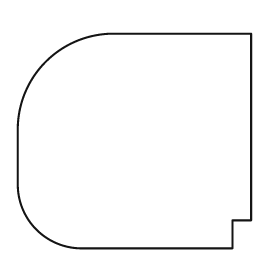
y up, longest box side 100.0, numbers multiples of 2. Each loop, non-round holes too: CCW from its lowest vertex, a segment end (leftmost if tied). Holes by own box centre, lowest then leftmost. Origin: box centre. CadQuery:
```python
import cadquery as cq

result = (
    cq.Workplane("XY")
    .moveTo(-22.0, -46.0)
    .lineTo(42.0, -46.0)
    .lineTo(42.0, -34.0)
    .lineTo(50.0, -34.0)
    .lineTo(50.0, 46.0)
    .lineTo(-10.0, 46.0)
    .threePointArc((-38.0, 34.0), (-50.0, 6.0))
    .lineTo(-50.0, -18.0)
    .threePointArc((-42.0, -38.0), (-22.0, -46.0))
    .close()
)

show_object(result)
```